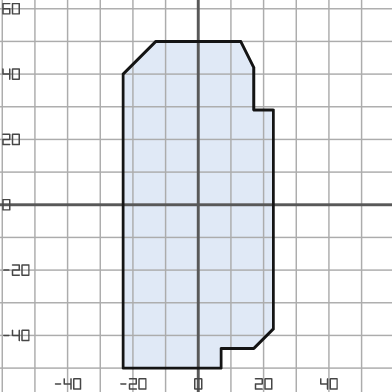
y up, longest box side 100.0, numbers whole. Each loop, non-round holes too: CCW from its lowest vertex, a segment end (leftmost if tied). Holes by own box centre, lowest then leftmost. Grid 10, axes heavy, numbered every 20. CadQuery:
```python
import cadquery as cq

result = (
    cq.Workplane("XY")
    .moveTo(-23.0, -50.0)
    .lineTo(7.0, -50.0)
    .lineTo(7.0, -44.0)
    .lineTo(17.0, -44.0)
    .lineTo(23.0, -38.0)
    .lineTo(23.0, 29.0)
    .lineTo(17.0, 29.0)
    .lineTo(17.0, 42.0)
    .lineTo(13.0, 50.0)
    .lineTo(-13.0, 50.0)
    .lineTo(-23.0, 40.0)
    .close()
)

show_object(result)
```